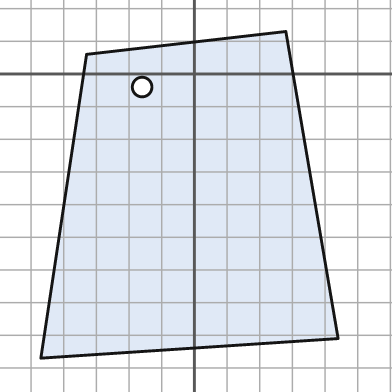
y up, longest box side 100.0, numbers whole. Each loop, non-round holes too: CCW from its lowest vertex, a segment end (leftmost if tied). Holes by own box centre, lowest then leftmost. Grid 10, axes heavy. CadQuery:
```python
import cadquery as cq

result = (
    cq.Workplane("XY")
    .moveTo(-47.0, -87.0)
    .lineTo(44.0, -81.0)
    .lineTo(28.0, 13.0)
    .lineTo(-33.0, 6.0)
    .close()
    .moveTo(-16.0, -4.0)
    .circle(3.0)
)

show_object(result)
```